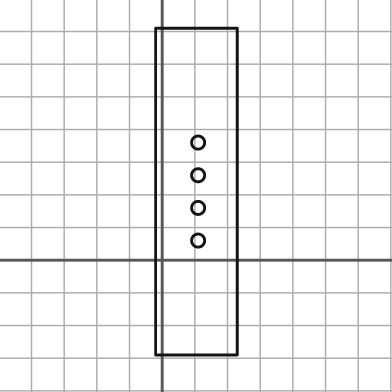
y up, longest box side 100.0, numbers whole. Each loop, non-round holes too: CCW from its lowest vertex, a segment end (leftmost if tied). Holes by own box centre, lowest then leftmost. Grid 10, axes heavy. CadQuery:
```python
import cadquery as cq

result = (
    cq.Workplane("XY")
    .moveTo(-2.0, -29.0)
    .lineTo(23.0, -29.0)
    .lineTo(23.0, 71.0)
    .lineTo(-2.0, 71.0)
    .close()
    .moveTo(11.0, 6.0)
    .circle(2.0)
    .moveTo(11.0, 16.0)
    .circle(2.0)
    .moveTo(11.0, 26.0)
    .circle(2.0)
    .moveTo(11.0, 36.0)
    .circle(2.0)
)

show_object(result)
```